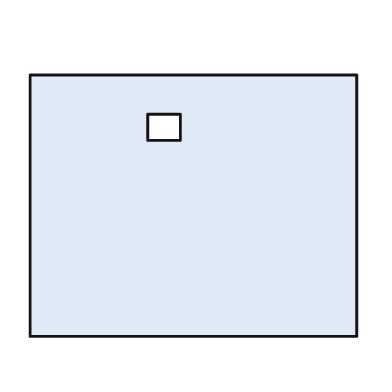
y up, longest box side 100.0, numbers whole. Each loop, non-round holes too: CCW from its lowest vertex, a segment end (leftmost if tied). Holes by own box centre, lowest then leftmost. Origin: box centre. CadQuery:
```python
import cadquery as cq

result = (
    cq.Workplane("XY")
    .moveTo(-50.0, -40.0)
    .lineTo(50.0, -40.0)
    .lineTo(50.0, 40.0)
    .lineTo(-50.0, 40.0)
    .close()
    .moveTo(-14.0, 20.0)
    .lineTo(-4.0, 20.0)
    .lineTo(-4.0, 28.0)
    .lineTo(-14.0, 28.0)
    .close()
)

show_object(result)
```